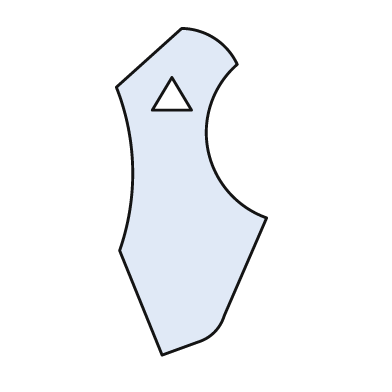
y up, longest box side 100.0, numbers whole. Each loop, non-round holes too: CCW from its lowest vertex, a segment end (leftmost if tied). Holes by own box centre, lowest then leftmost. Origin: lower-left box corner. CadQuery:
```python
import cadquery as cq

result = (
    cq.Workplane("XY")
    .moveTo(14.0, 0.0)
    .lineTo(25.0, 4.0)
    .threePointArc((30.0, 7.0), (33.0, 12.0))
    .lineTo(46.0, 42.0)
    .threePointArc((28.0, 63.0), (37.0, 89.0))
    .threePointArc((30.0, 97.0), (20.0, 100.0))
    .lineTo(0.0, 82.0)
    .threePointArc((5.0, 57.0), (1.0, 32.0))
    .close()
    .moveTo(11.0, 75.0)
    .lineTo(23.0, 75.0)
    .lineTo(17.0, 85.0)
    .close()
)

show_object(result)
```